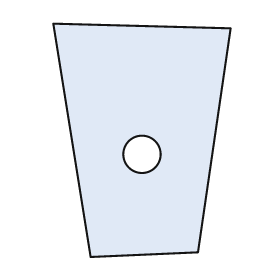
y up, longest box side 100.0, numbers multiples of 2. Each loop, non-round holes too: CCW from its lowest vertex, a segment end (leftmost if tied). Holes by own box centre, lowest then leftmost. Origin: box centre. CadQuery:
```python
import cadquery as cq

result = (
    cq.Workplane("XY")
    .moveTo(-22.0, -50.0)
    .lineTo(24.0, -48.0)
    .lineTo(38.0, 48.0)
    .lineTo(-38.0, 50.0)
    .close()
    .moveTo(0.0, -6.0)
    .circle(8.0)
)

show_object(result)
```